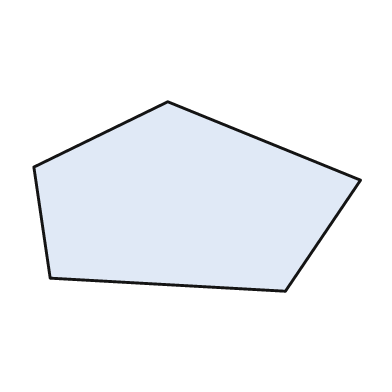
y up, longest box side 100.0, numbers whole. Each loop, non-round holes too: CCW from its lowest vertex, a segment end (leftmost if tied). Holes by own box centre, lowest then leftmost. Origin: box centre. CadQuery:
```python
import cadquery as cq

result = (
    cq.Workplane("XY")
    .moveTo(27.0, -29.0)
    .lineTo(50.0, 5.0)
    .lineTo(-9.0, 29.0)
    .lineTo(-50.0, 9.0)
    .lineTo(-45.0, -25.0)
    .close()
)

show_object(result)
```